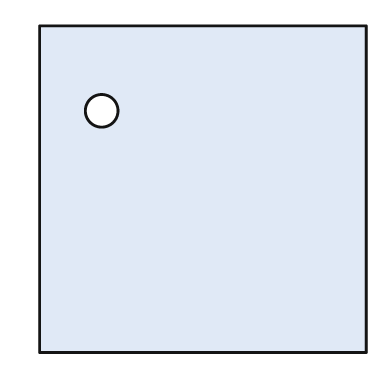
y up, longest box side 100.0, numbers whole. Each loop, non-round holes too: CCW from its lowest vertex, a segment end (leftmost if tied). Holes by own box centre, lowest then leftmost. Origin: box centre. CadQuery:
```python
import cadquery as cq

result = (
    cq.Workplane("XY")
    .moveTo(-50.0, -50.0)
    .lineTo(50.0, -50.0)
    .lineTo(50.0, 50.0)
    .lineTo(-50.0, 50.0)
    .close()
    .moveTo(-31.0, 24.0)
    .circle(5.0)
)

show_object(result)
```